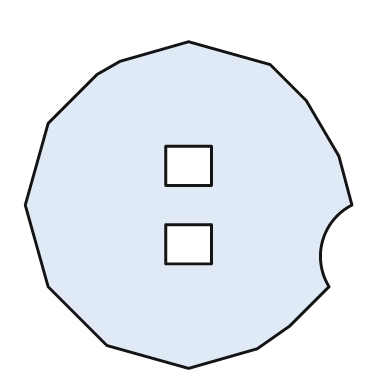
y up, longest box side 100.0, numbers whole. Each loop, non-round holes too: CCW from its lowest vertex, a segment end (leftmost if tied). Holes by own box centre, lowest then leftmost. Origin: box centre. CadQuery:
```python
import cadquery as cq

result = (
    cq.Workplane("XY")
    .moveTo(0.0, -50.0)
    .lineTo(21.0, -44.0)
    .lineTo(31.0, -37.0)
    .lineTo(43.0, -25.0)
    .threePointArc((41.0, -11.0), (50.0, 0.0))
    .lineTo(46.0, 15.0)
    .lineTo(36.0, 32.0)
    .lineTo(25.0, 43.0)
    .lineTo(0.0, 50.0)
    .lineTo(-21.0, 44.0)
    .lineTo(-28.0, 40.0)
    .lineTo(-43.0, 25.0)
    .lineTo(-50.0, 0.0)
    .lineTo(-43.0, -25.0)
    .lineTo(-25.0, -43.0)
    .close()
    .moveTo(-7.0, -18.0)
    .lineTo(7.0, -18.0)
    .lineTo(7.0, -6.0)
    .lineTo(-7.0, -6.0)
    .close()
    .moveTo(-7.0, 6.0)
    .lineTo(7.0, 6.0)
    .lineTo(7.0, 18.0)
    .lineTo(-7.0, 18.0)
    .close()
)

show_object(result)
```